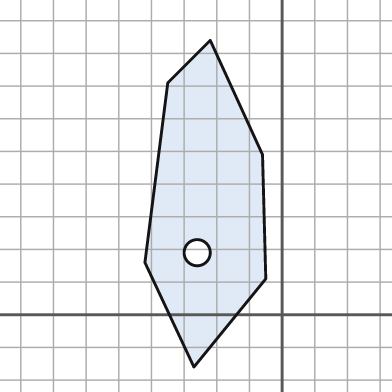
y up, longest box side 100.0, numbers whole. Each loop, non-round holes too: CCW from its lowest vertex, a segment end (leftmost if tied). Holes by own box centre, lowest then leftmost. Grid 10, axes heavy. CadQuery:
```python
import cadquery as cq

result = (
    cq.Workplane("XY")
    .moveTo(-27.0, -16.0)
    .lineTo(-5.0, 11.0)
    .lineTo(-6.0, 49.0)
    .lineTo(-22.0, 84.0)
    .lineTo(-35.0, 71.0)
    .lineTo(-42.0, 16.0)
    .close()
    .moveTo(-26.0, 19.0)
    .circle(4.0)
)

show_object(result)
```